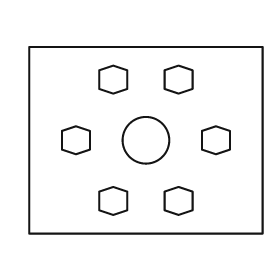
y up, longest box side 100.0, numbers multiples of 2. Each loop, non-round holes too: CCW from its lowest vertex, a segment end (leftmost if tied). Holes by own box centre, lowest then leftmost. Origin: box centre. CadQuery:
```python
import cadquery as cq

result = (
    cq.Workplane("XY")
    .moveTo(-50.0, -40.0)
    .lineTo(50.0, -40.0)
    .lineTo(50.0, 40.0)
    .lineTo(-50.0, 40.0)
    .close()
    .moveTo(-14.0, -32.0)
    .lineTo(-8.0, -30.0)
    .lineTo(-8.0, -22.0)
    .lineTo(-14.0, -20.0)
    .lineTo(-20.0, -22.0)
    .lineTo(-20.0, -30.0)
    .close()
    .moveTo(14.0, -32.0)
    .lineTo(20.0, -30.0)
    .lineTo(20.0, -22.0)
    .lineTo(14.0, -20.0)
    .lineTo(8.0, -22.0)
    .lineTo(8.0, -30.0)
    .close()
    .moveTo(-30.0, -6.0)
    .lineTo(-24.0, -4.0)
    .lineTo(-24.0, 4.0)
    .lineTo(-30.0, 6.0)
    .lineTo(-36.0, 4.0)
    .lineTo(-36.0, -4.0)
    .close()
    .moveTo(0.0, 0.0)
    .circle(10.0)
    .moveTo(30.0, -6.0)
    .lineTo(36.0, -4.0)
    .lineTo(36.0, 4.0)
    .lineTo(30.0, 6.0)
    .lineTo(24.0, 4.0)
    .lineTo(24.0, -4.0)
    .close()
    .moveTo(-14.0, 20.0)
    .lineTo(-8.0, 22.0)
    .lineTo(-8.0, 30.0)
    .lineTo(-14.0, 32.0)
    .lineTo(-20.0, 30.0)
    .lineTo(-20.0, 22.0)
    .close()
    .moveTo(14.0, 20.0)
    .lineTo(20.0, 22.0)
    .lineTo(20.0, 30.0)
    .lineTo(14.0, 32.0)
    .lineTo(8.0, 30.0)
    .lineTo(8.0, 22.0)
    .close()
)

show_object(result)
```